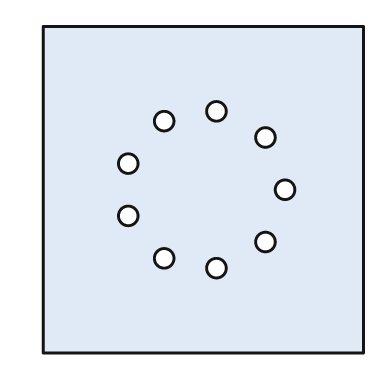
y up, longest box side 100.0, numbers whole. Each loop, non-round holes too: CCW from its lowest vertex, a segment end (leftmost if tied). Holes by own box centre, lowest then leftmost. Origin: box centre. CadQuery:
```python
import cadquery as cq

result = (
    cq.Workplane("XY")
    .moveTo(-49.0, -50.0)
    .lineTo(49.0, -50.0)
    .lineTo(49.0, 50.0)
    .lineTo(-49.0, 50.0)
    .close()
    .moveTo(4.0, -24.0)
    .circle(3.0)
    .moveTo(-12.0, -21.0)
    .circle(3.0)
    .moveTo(19.0, -16.0)
    .circle(3.0)
    .moveTo(-23.0, -8.0)
    .circle(3.0)
    .moveTo(25.0, 0.0)
    .circle(3.0)
    .moveTo(-23.0, 8.0)
    .circle(3.0)
    .moveTo(19.0, 16.0)
    .circle(3.0)
    .moveTo(-12.0, 21.0)
    .circle(3.0)
    .moveTo(4.0, 24.0)
    .circle(3.0)
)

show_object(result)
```